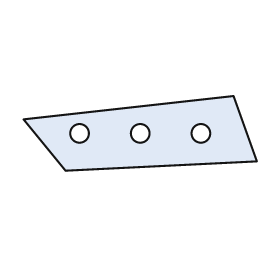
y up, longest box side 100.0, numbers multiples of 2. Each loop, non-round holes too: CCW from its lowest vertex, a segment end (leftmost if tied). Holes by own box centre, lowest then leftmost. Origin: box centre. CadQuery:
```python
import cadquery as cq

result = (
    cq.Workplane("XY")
    .moveTo(-32.0, -16.0)
    .lineTo(50.0, -12.0)
    .lineTo(40.0, 16.0)
    .lineTo(-50.0, 6.0)
    .close()
    .moveTo(-26.0, 0.0)
    .circle(4.0)
    .moveTo(0.0, 0.0)
    .circle(4.0)
    .moveTo(26.0, 0.0)
    .circle(4.0)
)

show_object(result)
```